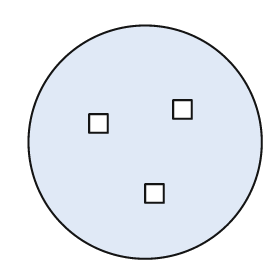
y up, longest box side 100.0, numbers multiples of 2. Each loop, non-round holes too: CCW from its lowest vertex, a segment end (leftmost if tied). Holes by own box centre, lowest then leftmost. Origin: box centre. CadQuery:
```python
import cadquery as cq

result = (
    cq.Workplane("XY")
    .moveTo(0.0, 0.0)
    .circle(50.0)
    .moveTo(0.0, -26.0)
    .lineTo(8.0, -26.0)
    .lineTo(8.0, -18.0)
    .lineTo(0.0, -18.0)
    .close()
    .moveTo(-24.0, 4.0)
    .lineTo(-16.0, 4.0)
    .lineTo(-16.0, 12.0)
    .lineTo(-24.0, 12.0)
    .close()
    .moveTo(12.0, 10.0)
    .lineTo(20.0, 10.0)
    .lineTo(20.0, 18.0)
    .lineTo(12.0, 18.0)
    .close()
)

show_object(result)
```